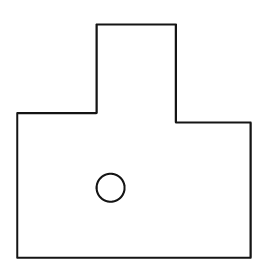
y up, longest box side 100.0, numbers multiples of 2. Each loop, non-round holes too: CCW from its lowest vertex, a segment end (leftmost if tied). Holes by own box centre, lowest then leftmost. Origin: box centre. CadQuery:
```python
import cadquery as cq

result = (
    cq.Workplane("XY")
    .moveTo(-50.0, -50.0)
    .lineTo(50.0, -50.0)
    .lineTo(50.0, 8.0)
    .lineTo(18.0, 8.0)
    .lineTo(18.0, 50.0)
    .lineTo(-16.0, 50.0)
    .lineTo(-16.0, 12.0)
    .lineTo(-50.0, 12.0)
    .close()
    .moveTo(-10.0, -20.0)
    .circle(6.0)
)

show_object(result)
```